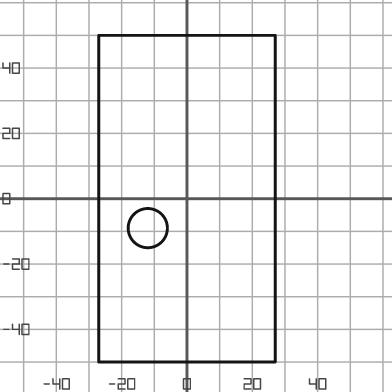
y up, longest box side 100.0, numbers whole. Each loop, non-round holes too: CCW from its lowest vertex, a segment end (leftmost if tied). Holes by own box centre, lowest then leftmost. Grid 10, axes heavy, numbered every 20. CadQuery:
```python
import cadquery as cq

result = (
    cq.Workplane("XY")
    .moveTo(-27.0, -50.0)
    .lineTo(27.0, -50.0)
    .lineTo(27.0, 50.0)
    .lineTo(-27.0, 50.0)
    .close()
    .moveTo(-12.0, -9.0)
    .circle(6.0)
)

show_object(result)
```